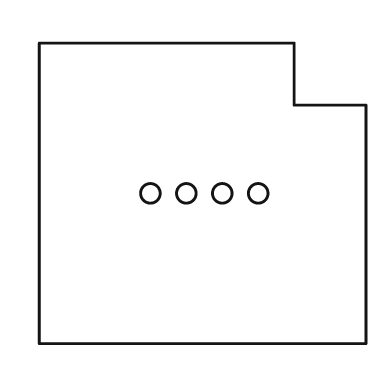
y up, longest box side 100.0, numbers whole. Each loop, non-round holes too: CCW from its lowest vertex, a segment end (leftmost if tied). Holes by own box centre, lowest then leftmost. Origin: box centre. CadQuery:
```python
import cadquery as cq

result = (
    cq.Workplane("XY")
    .moveTo(-50.0, -46.0)
    .lineTo(50.0, -46.0)
    .lineTo(50.0, 27.0)
    .lineTo(28.0, 27.0)
    .lineTo(28.0, 46.0)
    .lineTo(-50.0, 46.0)
    .close()
    .moveTo(-16.0, 0.0)
    .circle(3.0)
    .moveTo(-5.0, 0.0)
    .circle(3.0)
    .moveTo(6.0, 0.0)
    .circle(3.0)
    .moveTo(17.0, 0.0)
    .circle(3.0)
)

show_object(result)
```